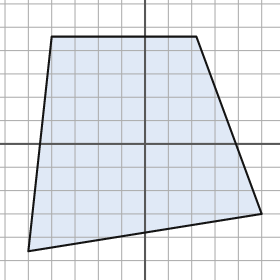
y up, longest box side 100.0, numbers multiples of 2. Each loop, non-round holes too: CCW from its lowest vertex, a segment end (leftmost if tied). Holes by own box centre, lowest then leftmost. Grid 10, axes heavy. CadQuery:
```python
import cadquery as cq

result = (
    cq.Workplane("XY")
    .moveTo(-50.0, -46.0)
    .lineTo(50.0, -30.0)
    .lineTo(22.0, 46.0)
    .lineTo(-40.0, 46.0)
    .close()
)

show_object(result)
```